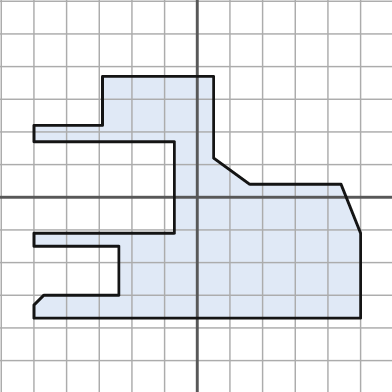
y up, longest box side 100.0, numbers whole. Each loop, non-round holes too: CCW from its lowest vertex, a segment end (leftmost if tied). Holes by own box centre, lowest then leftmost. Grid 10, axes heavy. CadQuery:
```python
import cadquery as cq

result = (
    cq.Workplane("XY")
    .moveTo(-50.0, -37.0)
    .lineTo(50.0, -37.0)
    .lineTo(50.0, -11.0)
    .lineTo(44.0, 4.0)
    .lineTo(16.0, 4.0)
    .lineTo(5.0, 12.0)
    .lineTo(5.0, 37.0)
    .lineTo(-29.0, 37.0)
    .lineTo(-29.0, 22.0)
    .lineTo(-50.0, 22.0)
    .lineTo(-50.0, 17.0)
    .lineTo(-7.0, 17.0)
    .lineTo(-7.0, -11.0)
    .lineTo(-50.0, -11.0)
    .lineTo(-50.0, -15.0)
    .lineTo(-24.0, -15.0)
    .lineTo(-24.0, -30.0)
    .lineTo(-47.0, -30.0)
    .lineTo(-50.0, -33.0)
    .close()
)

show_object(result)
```